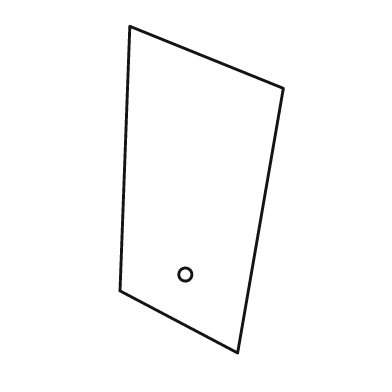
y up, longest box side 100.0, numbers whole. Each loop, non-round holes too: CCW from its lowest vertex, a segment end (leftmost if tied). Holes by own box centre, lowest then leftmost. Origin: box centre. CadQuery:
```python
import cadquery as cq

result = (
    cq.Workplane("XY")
    .moveTo(11.0, -50.0)
    .lineTo(25.0, 31.0)
    .lineTo(-22.0, 50.0)
    .lineTo(-25.0, -31.0)
    .close()
    .moveTo(-5.0, -26.0)
    .circle(2.0)
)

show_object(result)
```